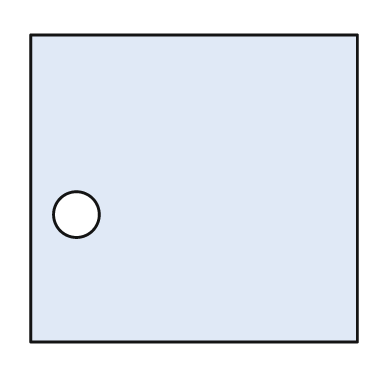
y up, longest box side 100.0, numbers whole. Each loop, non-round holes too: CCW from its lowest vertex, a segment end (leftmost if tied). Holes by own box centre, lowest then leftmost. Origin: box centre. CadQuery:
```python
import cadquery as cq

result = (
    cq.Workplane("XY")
    .moveTo(-50.0, -47.0)
    .lineTo(50.0, -47.0)
    .lineTo(50.0, 47.0)
    .lineTo(-50.0, 47.0)
    .close()
    .moveTo(-36.0, -8.0)
    .circle(7.0)
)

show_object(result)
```